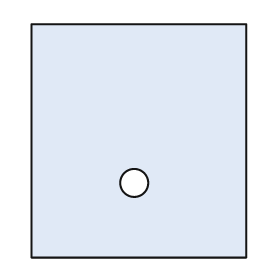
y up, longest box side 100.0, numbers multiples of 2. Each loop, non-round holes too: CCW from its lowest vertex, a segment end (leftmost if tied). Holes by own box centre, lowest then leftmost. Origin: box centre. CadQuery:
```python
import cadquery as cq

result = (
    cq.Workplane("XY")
    .moveTo(-46.0, -50.0)
    .lineTo(46.0, -50.0)
    .lineTo(46.0, 50.0)
    .lineTo(-46.0, 50.0)
    .close()
    .moveTo(-2.0, -18.0)
    .circle(6.0)
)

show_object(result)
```